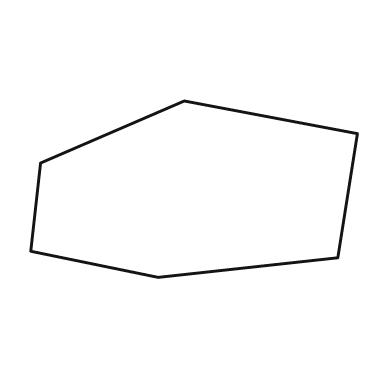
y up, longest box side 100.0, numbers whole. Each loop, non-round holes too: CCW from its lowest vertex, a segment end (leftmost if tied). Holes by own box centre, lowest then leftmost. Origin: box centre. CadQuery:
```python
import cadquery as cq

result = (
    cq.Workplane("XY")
    .moveTo(-11.0, -27.0)
    .lineTo(44.0, -21.0)
    .lineTo(50.0, 17.0)
    .lineTo(-3.0, 27.0)
    .lineTo(-47.0, 8.0)
    .lineTo(-50.0, -19.0)
    .close()
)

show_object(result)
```